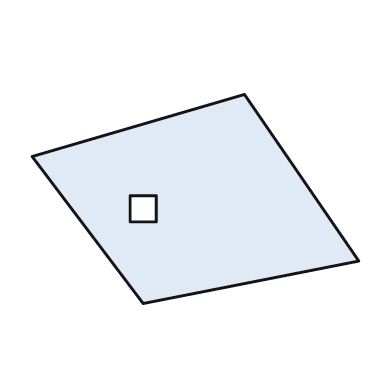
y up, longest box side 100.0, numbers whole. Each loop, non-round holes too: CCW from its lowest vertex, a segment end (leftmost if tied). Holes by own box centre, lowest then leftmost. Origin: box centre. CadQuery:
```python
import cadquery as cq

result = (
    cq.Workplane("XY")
    .moveTo(-16.0, -32.0)
    .lineTo(50.0, -19.0)
    .lineTo(15.0, 32.0)
    .lineTo(-50.0, 13.0)
    .close()
    .moveTo(-20.0, -7.0)
    .lineTo(-12.0, -7.0)
    .lineTo(-12.0, 1.0)
    .lineTo(-20.0, 1.0)
    .close()
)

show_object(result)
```